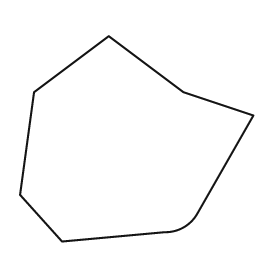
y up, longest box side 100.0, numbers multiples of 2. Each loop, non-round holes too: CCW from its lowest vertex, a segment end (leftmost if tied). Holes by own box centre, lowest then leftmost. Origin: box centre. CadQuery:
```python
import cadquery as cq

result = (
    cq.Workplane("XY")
    .moveTo(-32.0, -44.0)
    .lineTo(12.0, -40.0)
    .threePointArc((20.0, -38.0), (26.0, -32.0))
    .lineTo(50.0, 10.0)
    .lineTo(20.0, 20.0)
    .lineTo(-12.0, 44.0)
    .lineTo(-44.0, 20.0)
    .lineTo(-50.0, -24.0)
    .close()
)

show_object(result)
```